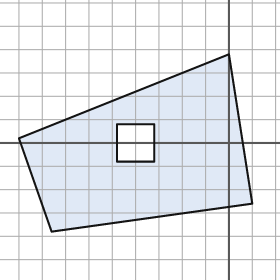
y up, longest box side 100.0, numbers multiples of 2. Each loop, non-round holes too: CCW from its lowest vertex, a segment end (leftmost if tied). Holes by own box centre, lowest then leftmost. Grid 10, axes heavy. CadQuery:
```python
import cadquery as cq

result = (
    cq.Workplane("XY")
    .moveTo(-76.0, -38.0)
    .lineTo(10.0, -26.0)
    .lineTo(0.0, 38.0)
    .lineTo(-90.0, 2.0)
    .close()
    .moveTo(-48.0, -8.0)
    .lineTo(-32.0, -8.0)
    .lineTo(-32.0, 8.0)
    .lineTo(-48.0, 8.0)
    .close()
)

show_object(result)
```